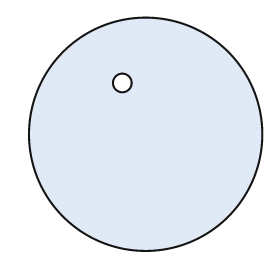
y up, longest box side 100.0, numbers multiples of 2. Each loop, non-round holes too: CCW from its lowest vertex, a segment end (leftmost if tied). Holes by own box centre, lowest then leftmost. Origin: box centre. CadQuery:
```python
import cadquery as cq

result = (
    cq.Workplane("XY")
    .moveTo(0.0, 0.0)
    .circle(50.0)
    .moveTo(-10.0, 22.0)
    .circle(4.0)
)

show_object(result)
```